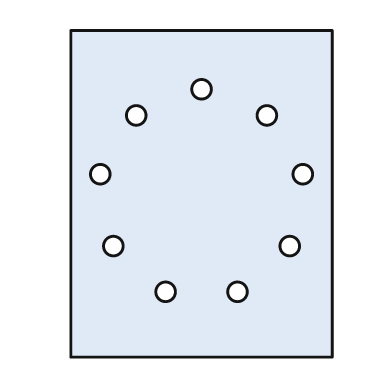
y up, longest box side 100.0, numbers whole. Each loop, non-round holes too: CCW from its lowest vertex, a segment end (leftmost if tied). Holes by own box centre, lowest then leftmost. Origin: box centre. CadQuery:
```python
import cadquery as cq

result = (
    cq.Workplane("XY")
    .moveTo(-40.0, -50.0)
    .lineTo(40.0, -50.0)
    .lineTo(40.0, 50.0)
    .lineTo(-40.0, 50.0)
    .close()
    .moveTo(-11.0, -30.0)
    .circle(3.0)
    .moveTo(11.0, -30.0)
    .circle(3.0)
    .moveTo(-27.0, -16.0)
    .circle(3.0)
    .moveTo(27.0, -16.0)
    .circle(3.0)
    .moveTo(-31.0, 6.0)
    .circle(3.0)
    .moveTo(31.0, 6.0)
    .circle(3.0)
    .moveTo(-20.0, 24.0)
    .circle(3.0)
    .moveTo(20.0, 24.0)
    .circle(3.0)
    .moveTo(0.0, 32.0)
    .circle(3.0)
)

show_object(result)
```